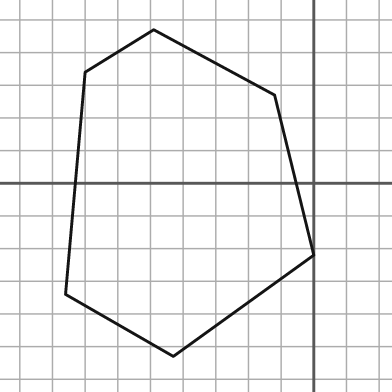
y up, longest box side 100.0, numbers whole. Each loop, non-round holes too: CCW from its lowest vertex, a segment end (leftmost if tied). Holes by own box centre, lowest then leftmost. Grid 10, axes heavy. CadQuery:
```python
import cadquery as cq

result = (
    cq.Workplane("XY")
    .moveTo(-43.0, -53.0)
    .lineTo(0.0, -22.0)
    .lineTo(-12.0, 27.0)
    .lineTo(-49.0, 47.0)
    .lineTo(-70.0, 34.0)
    .lineTo(-76.0, -34.0)
    .close()
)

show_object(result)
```